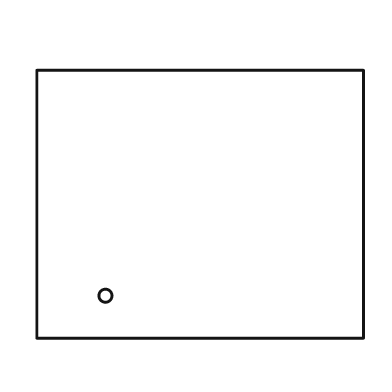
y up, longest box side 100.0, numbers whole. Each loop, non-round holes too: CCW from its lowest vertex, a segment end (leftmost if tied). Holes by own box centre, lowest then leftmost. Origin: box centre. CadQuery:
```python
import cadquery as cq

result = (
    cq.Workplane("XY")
    .moveTo(-50.0, -41.0)
    .lineTo(50.0, -41.0)
    .lineTo(50.0, 41.0)
    .lineTo(-50.0, 41.0)
    .close()
    .moveTo(-29.0, -28.0)
    .circle(2.0)
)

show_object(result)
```